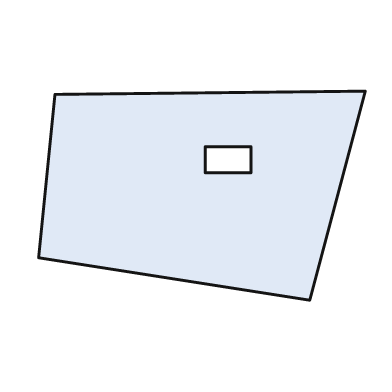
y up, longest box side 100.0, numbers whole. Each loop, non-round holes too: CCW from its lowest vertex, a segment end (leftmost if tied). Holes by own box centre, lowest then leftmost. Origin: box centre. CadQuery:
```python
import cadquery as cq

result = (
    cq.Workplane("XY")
    .moveTo(33.0, -32.0)
    .lineTo(50.0, 32.0)
    .lineTo(-45.0, 31.0)
    .lineTo(-50.0, -19.0)
    .close()
    .moveTo(1.0, 7.0)
    .lineTo(15.0, 7.0)
    .lineTo(15.0, 15.0)
    .lineTo(1.0, 15.0)
    .close()
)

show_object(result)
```